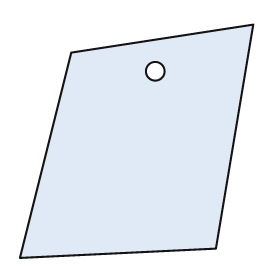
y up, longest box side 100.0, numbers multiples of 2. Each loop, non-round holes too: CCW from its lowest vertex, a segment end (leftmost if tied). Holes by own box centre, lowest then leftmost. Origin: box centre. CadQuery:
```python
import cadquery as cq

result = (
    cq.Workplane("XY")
    .moveTo(-50.0, -50.0)
    .lineTo(34.0, -46.0)
    .lineTo(50.0, 50.0)
    .lineTo(-28.0, 38.0)
    .close()
    .moveTo(8.0, 30.0)
    .circle(4.0)
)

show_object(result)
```